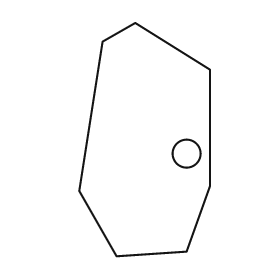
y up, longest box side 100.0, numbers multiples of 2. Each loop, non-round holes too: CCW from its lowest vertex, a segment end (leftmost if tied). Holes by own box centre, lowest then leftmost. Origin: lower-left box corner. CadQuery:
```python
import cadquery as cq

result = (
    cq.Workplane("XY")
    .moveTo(16.0, 0.0)
    .lineTo(46.0, 2.0)
    .lineTo(56.0, 30.0)
    .lineTo(56.0, 80.0)
    .lineTo(24.0, 100.0)
    .lineTo(10.0, 92.0)
    .lineTo(0.0, 28.0)
    .close()
    .moveTo(46.0, 44.0)
    .circle(6.0)
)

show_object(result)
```